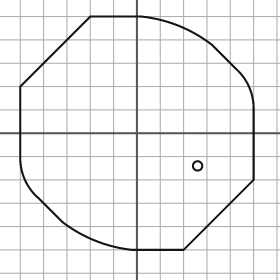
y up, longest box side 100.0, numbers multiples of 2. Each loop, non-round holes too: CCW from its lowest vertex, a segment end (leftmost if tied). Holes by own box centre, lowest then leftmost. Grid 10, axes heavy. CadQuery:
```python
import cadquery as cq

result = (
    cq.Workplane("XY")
    .moveTo(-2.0, -50.0)
    .lineTo(20.0, -50.0)
    .lineTo(50.0, -20.0)
    .lineTo(50.0, 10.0)
    .threePointArc((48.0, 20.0), (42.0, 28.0))
    .lineTo(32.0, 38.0)
    .threePointArc((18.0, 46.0), (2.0, 50.0))
    .lineTo(-20.0, 50.0)
    .lineTo(-50.0, 20.0)
    .lineTo(-50.0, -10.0)
    .threePointArc((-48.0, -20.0), (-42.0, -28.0))
    .lineTo(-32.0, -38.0)
    .threePointArc((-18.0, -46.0), (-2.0, -50.0))
    .close()
    .moveTo(26.0, -14.0)
    .circle(2.0)
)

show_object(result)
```